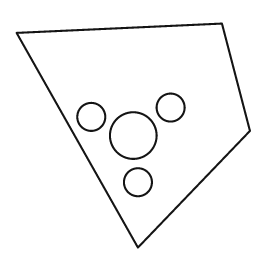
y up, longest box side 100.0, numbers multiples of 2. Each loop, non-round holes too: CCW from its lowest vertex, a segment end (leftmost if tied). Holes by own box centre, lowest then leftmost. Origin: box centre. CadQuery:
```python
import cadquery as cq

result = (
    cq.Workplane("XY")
    .moveTo(2.0, -48.0)
    .lineTo(50.0, 2.0)
    .lineTo(38.0, 48.0)
    .lineTo(-50.0, 44.0)
    .close()
    .moveTo(2.0, -20.0)
    .circle(6.0)
    .moveTo(0.0, 0.0)
    .circle(10.0)
    .moveTo(-18.0, 8.0)
    .circle(6.0)
    .moveTo(16.0, 12.0)
    .circle(6.0)
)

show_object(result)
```